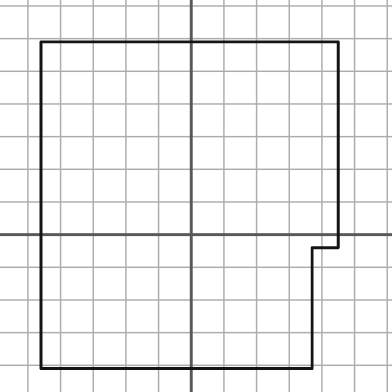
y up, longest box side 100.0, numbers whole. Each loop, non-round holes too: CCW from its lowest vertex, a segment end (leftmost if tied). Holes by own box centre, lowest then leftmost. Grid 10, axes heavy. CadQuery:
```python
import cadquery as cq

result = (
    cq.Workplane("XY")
    .moveTo(-46.0, -41.0)
    .lineTo(37.0, -41.0)
    .lineTo(37.0, -4.0)
    .lineTo(45.0, -4.0)
    .lineTo(45.0, 59.0)
    .lineTo(-46.0, 59.0)
    .close()
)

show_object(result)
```